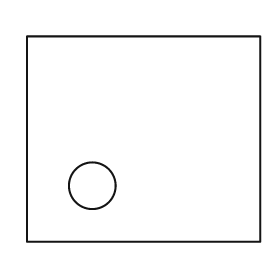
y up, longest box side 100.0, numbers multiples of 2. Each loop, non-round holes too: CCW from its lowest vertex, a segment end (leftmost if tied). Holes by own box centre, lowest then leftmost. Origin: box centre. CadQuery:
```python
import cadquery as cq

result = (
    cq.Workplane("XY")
    .moveTo(-50.0, -44.0)
    .lineTo(50.0, -44.0)
    .lineTo(50.0, 44.0)
    .lineTo(-50.0, 44.0)
    .close()
    .moveTo(-22.0, -20.0)
    .circle(10.0)
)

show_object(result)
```